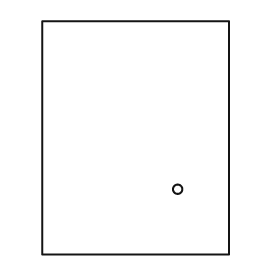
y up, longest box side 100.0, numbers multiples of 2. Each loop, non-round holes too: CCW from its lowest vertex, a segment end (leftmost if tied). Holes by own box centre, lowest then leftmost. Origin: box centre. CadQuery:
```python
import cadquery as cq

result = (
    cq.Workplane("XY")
    .moveTo(-40.0, -50.0)
    .lineTo(40.0, -50.0)
    .lineTo(40.0, 50.0)
    .lineTo(-40.0, 50.0)
    .close()
    .moveTo(18.0, -22.0)
    .circle(2.0)
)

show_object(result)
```